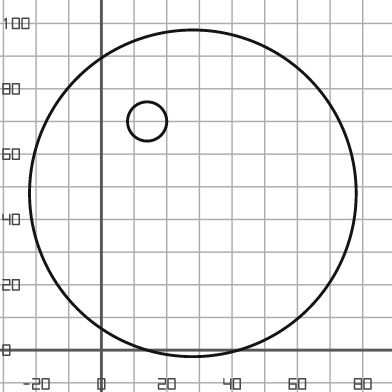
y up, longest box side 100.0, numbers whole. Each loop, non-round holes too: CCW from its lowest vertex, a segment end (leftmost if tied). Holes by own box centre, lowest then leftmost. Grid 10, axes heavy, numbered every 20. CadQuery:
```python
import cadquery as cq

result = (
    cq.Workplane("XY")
    .moveTo(28.0, 48.0)
    .circle(50.0)
    .moveTo(14.0, 70.0)
    .circle(6.0)
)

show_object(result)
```